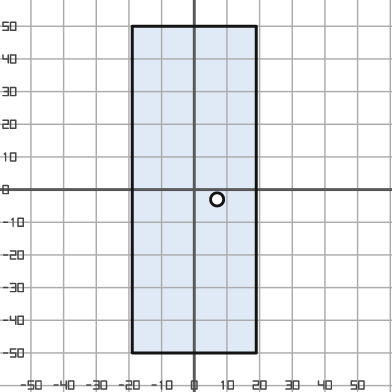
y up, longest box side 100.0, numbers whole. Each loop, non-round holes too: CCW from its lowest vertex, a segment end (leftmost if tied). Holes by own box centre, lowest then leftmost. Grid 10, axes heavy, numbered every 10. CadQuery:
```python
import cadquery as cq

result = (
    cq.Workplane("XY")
    .moveTo(-19.0, -50.0)
    .lineTo(19.0, -50.0)
    .lineTo(19.0, 50.0)
    .lineTo(-19.0, 50.0)
    .close()
    .moveTo(7.0, -3.0)
    .circle(2.0)
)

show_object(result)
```